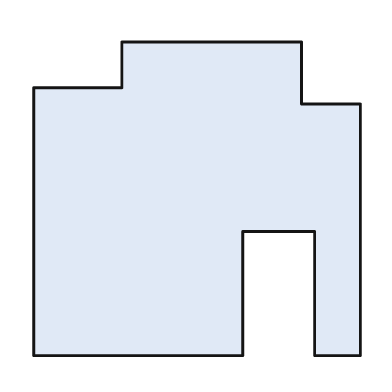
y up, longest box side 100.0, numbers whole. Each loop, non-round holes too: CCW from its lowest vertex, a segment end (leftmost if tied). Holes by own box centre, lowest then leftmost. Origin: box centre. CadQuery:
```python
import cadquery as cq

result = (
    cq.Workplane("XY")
    .moveTo(-50.0, -48.0)
    .lineTo(14.0, -48.0)
    .lineTo(14.0, -10.0)
    .lineTo(36.0, -10.0)
    .lineTo(36.0, -48.0)
    .lineTo(50.0, -48.0)
    .lineTo(50.0, 29.0)
    .lineTo(32.0, 29.0)
    .lineTo(32.0, 48.0)
    .lineTo(-23.0, 48.0)
    .lineTo(-23.0, 34.0)
    .lineTo(-50.0, 34.0)
    .close()
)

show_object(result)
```